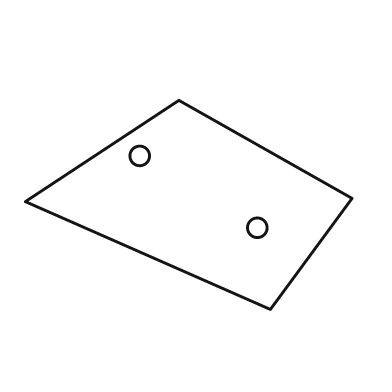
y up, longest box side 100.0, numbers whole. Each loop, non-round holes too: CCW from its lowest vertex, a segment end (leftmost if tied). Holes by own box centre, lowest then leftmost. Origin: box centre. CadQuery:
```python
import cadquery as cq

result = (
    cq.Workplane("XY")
    .moveTo(25.0, -32.0)
    .lineTo(50.0, 2.0)
    .lineTo(-3.0, 32.0)
    .lineTo(-50.0, 1.0)
    .close()
    .moveTo(21.0, -7.0)
    .circle(3.0)
    .moveTo(-15.0, 15.0)
    .circle(3.0)
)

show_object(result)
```